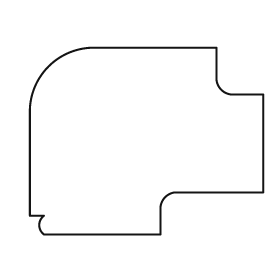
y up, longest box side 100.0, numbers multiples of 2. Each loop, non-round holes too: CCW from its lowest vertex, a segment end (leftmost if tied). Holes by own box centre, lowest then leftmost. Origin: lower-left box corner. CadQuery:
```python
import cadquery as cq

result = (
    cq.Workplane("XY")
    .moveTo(6.0, 0.0)
    .lineTo(56.0, 0.0)
    .lineTo(56.0, 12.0)
    .threePointArc((58.0, 16.0), (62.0, 18.0))
    .lineTo(100.0, 18.0)
    .lineTo(100.0, 60.0)
    .lineTo(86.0, 60.0)
    .threePointArc((82.0, 62.0), (80.0, 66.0))
    .lineTo(80.0, 80.0)
    .lineTo(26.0, 80.0)
    .threePointArc((8.0, 72.0), (0.0, 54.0))
    .lineTo(0.0, 8.0)
    .lineTo(6.0, 8.0)
    .threePointArc((4.0, 4.0), (6.0, 0.0))
    .close()
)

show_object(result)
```